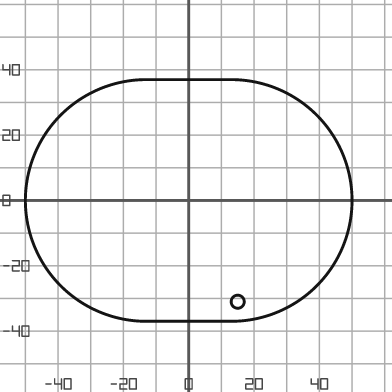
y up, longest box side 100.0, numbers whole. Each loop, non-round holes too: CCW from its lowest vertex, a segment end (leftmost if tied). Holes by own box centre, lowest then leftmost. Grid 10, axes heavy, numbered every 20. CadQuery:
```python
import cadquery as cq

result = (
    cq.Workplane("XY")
    .moveTo(-13.0, -37.0)
    .lineTo(13.0, -37.0)
    .threePointArc((50.0, 0.0), (13.0, 37.0))
    .lineTo(-13.0, 37.0)
    .threePointArc((-50.0, 0.0), (-13.0, -37.0))
    .close()
    .moveTo(15.0, -31.0)
    .circle(2.0)
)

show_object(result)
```